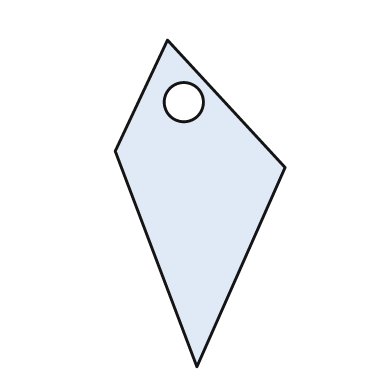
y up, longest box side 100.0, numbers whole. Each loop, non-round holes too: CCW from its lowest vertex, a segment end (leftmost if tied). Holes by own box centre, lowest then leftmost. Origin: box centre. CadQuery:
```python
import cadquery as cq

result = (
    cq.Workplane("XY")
    .moveTo(-1.0, -50.0)
    .lineTo(26.0, 11.0)
    .lineTo(-10.0, 50.0)
    .lineTo(-26.0, 16.0)
    .close()
    .moveTo(-5.0, 31.0)
    .circle(6.0)
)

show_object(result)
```